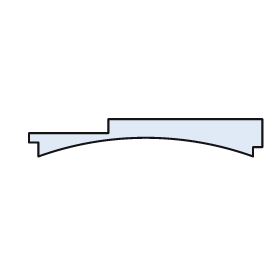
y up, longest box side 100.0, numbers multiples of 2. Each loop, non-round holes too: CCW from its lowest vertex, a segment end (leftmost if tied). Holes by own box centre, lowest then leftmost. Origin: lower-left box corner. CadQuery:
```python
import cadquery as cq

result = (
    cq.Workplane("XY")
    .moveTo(4.0, 0.0)
    .threePointArc((50.0, 8.0), (96.0, 0.0))
    .lineTo(96.0, 4.0)
    .lineTo(100.0, 4.0)
    .lineTo(100.0, 16.0)
    .lineTo(34.0, 16.0)
    .lineTo(34.0, 10.0)
    .lineTo(0.0, 10.0)
    .lineTo(0.0, 6.0)
    .lineTo(4.0, 6.0)
    .close()
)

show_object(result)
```